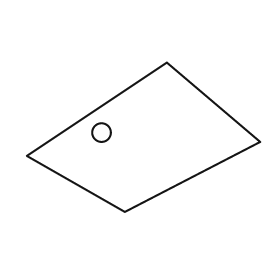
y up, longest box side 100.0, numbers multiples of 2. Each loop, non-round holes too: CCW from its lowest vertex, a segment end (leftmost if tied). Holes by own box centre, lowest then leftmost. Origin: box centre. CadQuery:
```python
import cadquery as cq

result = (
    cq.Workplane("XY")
    .moveTo(-8.0, -32.0)
    .lineTo(50.0, -2.0)
    .lineTo(10.0, 32.0)
    .lineTo(-50.0, -8.0)
    .close()
    .moveTo(-18.0, 2.0)
    .circle(4.0)
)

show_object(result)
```